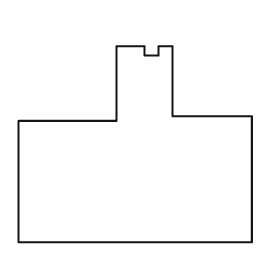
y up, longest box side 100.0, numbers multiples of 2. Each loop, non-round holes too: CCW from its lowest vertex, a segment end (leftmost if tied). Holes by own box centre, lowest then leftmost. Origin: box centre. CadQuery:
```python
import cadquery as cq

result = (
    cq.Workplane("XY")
    .moveTo(-50.0, -42.0)
    .lineTo(50.0, -42.0)
    .lineTo(50.0, 12.0)
    .lineTo(16.0, 12.0)
    .lineTo(16.0, 42.0)
    .lineTo(10.0, 42.0)
    .lineTo(10.0, 38.0)
    .lineTo(4.0, 38.0)
    .lineTo(4.0, 42.0)
    .lineTo(-8.0, 42.0)
    .lineTo(-8.0, 10.0)
    .lineTo(-50.0, 10.0)
    .close()
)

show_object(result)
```